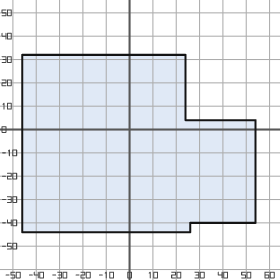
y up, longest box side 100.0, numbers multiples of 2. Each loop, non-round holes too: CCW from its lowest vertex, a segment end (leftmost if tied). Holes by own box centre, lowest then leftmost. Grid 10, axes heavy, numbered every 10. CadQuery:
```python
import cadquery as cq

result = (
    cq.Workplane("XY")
    .moveTo(-46.0, -44.0)
    .lineTo(26.0, -44.0)
    .lineTo(26.0, -40.0)
    .lineTo(54.0, -40.0)
    .lineTo(54.0, 4.0)
    .lineTo(24.0, 4.0)
    .lineTo(24.0, 32.0)
    .lineTo(-46.0, 32.0)
    .close()
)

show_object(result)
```